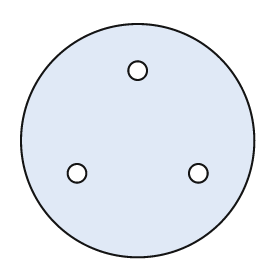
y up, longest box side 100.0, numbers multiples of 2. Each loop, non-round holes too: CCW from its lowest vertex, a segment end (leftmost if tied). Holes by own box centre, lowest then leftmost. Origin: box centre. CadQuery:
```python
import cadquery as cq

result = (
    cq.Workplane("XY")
    .moveTo(0.0, 0.0)
    .circle(50.0)
    .moveTo(-26.0, -14.0)
    .circle(4.0)
    .moveTo(26.0, -14.0)
    .circle(4.0)
    .moveTo(0.0, 30.0)
    .circle(4.0)
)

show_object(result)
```